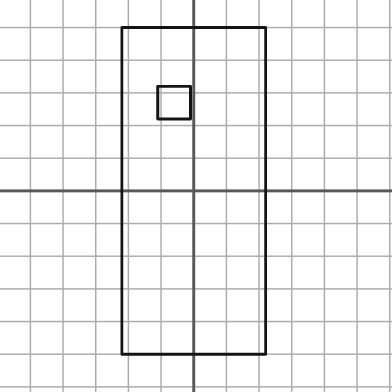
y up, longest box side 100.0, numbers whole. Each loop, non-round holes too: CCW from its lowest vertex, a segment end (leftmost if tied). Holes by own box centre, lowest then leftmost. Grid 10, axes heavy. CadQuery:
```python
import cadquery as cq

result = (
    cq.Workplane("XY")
    .moveTo(-22.0, -50.0)
    .lineTo(22.0, -50.0)
    .lineTo(22.0, 50.0)
    .lineTo(-22.0, 50.0)
    .close()
    .moveTo(-11.0, 22.0)
    .lineTo(-1.0, 22.0)
    .lineTo(-1.0, 32.0)
    .lineTo(-11.0, 32.0)
    .close()
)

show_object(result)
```